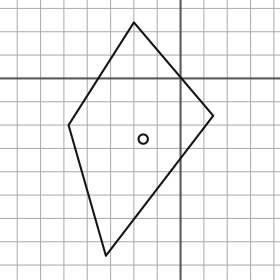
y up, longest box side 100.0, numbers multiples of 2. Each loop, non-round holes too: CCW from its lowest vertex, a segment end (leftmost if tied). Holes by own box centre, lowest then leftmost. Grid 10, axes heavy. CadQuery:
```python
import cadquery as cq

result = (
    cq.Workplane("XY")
    .moveTo(-32.0, -76.0)
    .lineTo(14.0, -16.0)
    .lineTo(-20.0, 24.0)
    .lineTo(-48.0, -20.0)
    .close()
    .moveTo(-16.0, -26.0)
    .circle(2.0)
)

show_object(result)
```